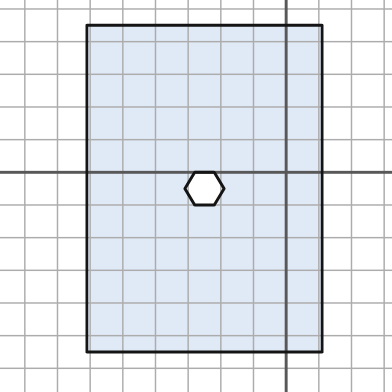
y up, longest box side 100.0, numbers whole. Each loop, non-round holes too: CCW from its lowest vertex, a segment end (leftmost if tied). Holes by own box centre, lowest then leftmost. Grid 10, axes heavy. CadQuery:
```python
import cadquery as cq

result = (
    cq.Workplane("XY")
    .moveTo(-61.0, -55.0)
    .lineTo(11.0, -55.0)
    .lineTo(11.0, 45.0)
    .lineTo(-61.0, 45.0)
    .close()
    .moveTo(-28.0, -10.0)
    .lineTo(-22.0, -10.0)
    .lineTo(-19.0, -5.0)
    .lineTo(-22.0, 0.0)
    .lineTo(-28.0, 0.0)
    .lineTo(-31.0, -5.0)
    .close()
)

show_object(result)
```